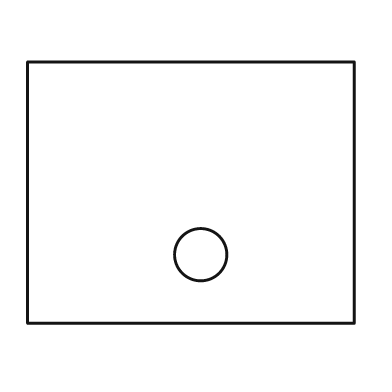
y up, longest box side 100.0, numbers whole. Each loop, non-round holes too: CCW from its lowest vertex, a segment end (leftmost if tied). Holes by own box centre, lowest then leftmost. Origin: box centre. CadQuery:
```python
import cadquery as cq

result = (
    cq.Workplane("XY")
    .moveTo(-50.0, -40.0)
    .lineTo(50.0, -40.0)
    .lineTo(50.0, 40.0)
    .lineTo(-50.0, 40.0)
    .close()
    .moveTo(3.0, -19.0)
    .circle(8.0)
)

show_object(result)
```